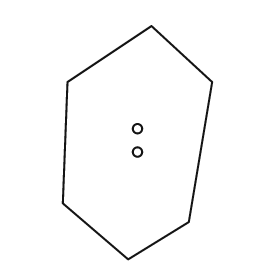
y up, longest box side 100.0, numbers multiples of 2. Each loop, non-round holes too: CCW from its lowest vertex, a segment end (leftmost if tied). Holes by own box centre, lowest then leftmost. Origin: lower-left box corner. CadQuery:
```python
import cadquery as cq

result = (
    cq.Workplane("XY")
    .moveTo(28.0, 0.0)
    .lineTo(54.0, 16.0)
    .lineTo(64.0, 76.0)
    .lineTo(38.0, 100.0)
    .lineTo(2.0, 76.0)
    .lineTo(0.0, 24.0)
    .close()
    .moveTo(32.0, 46.0)
    .circle(2.0)
    .moveTo(32.0, 56.0)
    .circle(2.0)
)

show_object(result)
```